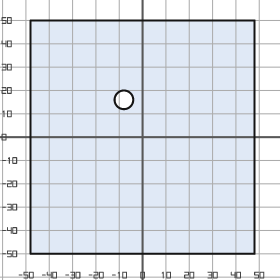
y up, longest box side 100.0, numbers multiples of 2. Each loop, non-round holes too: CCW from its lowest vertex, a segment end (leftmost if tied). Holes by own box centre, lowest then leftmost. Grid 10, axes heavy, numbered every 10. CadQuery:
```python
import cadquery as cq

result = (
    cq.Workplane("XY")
    .moveTo(-48.0, -50.0)
    .lineTo(48.0, -50.0)
    .lineTo(48.0, 50.0)
    .lineTo(-48.0, 50.0)
    .close()
    .moveTo(-8.0, 16.0)
    .circle(4.0)
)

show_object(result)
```